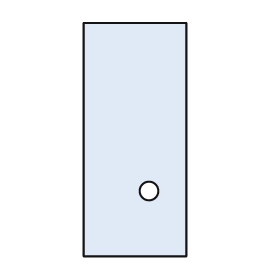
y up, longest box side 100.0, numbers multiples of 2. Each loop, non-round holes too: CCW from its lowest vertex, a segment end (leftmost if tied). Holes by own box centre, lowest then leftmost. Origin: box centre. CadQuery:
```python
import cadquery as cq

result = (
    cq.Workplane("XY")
    .moveTo(-22.0, -50.0)
    .lineTo(22.0, -50.0)
    .lineTo(22.0, 50.0)
    .lineTo(-22.0, 50.0)
    .close()
    .moveTo(6.0, -22.0)
    .circle(4.0)
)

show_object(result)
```